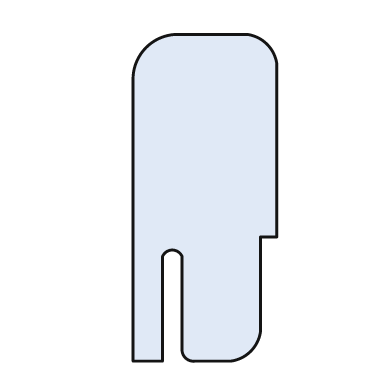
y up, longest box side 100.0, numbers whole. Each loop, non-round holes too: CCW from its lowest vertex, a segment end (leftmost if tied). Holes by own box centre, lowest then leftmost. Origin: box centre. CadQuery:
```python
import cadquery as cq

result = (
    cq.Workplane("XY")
    .moveTo(-22.0, -50.0)
    .lineTo(-13.0, -50.0)
    .lineTo(-13.0, -18.0)
    .threePointArc((-10.0, -16.0), (-7.0, -18.0))
    .lineTo(-7.0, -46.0)
    .threePointArc((-6.0, -49.0), (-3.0, -50.0))
    .lineTo(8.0, -50.0)
    .threePointArc((14.0, -47.0), (17.0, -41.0))
    .lineTo(17.0, -12.0)
    .lineTo(22.0, -12.0)
    .lineTo(22.0, 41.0)
    .threePointArc((19.0, 47.0), (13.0, 50.0))
    .lineTo(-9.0, 50.0)
    .threePointArc((-18.0, 46.0), (-22.0, 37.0))
    .close()
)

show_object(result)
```